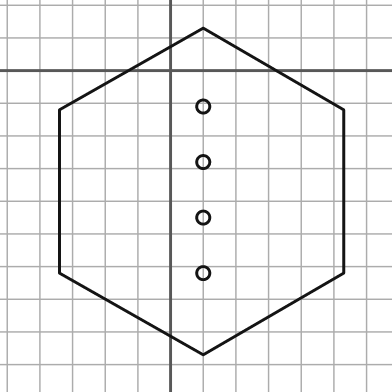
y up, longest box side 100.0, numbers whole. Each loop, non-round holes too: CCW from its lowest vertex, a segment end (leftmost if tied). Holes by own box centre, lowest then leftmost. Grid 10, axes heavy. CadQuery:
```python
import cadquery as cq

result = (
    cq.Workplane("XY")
    .moveTo(10.0, -87.0)
    .lineTo(53.0, -62.0)
    .lineTo(53.0, -12.0)
    .lineTo(10.0, 13.0)
    .lineTo(-34.0, -12.0)
    .lineTo(-34.0, -62.0)
    .close()
    .moveTo(10.0, -62.0)
    .circle(2.0)
    .moveTo(10.0, -45.0)
    .circle(2.0)
    .moveTo(10.0, -28.0)
    .circle(2.0)
    .moveTo(10.0, -11.0)
    .circle(2.0)
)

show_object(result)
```